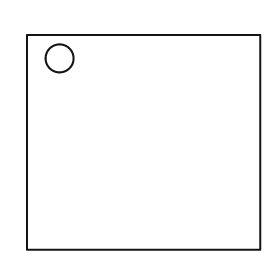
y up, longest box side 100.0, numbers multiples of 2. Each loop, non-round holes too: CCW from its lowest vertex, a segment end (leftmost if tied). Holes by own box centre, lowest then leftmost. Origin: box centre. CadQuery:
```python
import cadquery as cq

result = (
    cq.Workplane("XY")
    .moveTo(-50.0, -46.0)
    .lineTo(50.0, -46.0)
    .lineTo(50.0, 46.0)
    .lineTo(-50.0, 46.0)
    .close()
    .moveTo(-36.0, 36.0)
    .circle(6.0)
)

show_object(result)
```